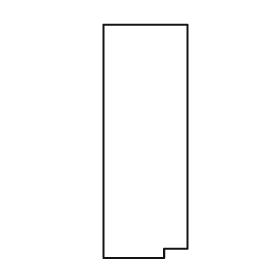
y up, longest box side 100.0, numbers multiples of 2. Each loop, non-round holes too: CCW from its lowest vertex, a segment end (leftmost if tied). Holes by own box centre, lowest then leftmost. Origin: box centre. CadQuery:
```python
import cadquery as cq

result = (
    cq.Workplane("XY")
    .moveTo(-18.0, -50.0)
    .lineTo(8.0, -50.0)
    .lineTo(8.0, -46.0)
    .lineTo(18.0, -46.0)
    .lineTo(18.0, 50.0)
    .lineTo(-18.0, 50.0)
    .close()
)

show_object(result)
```